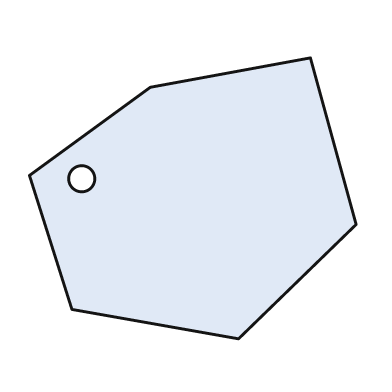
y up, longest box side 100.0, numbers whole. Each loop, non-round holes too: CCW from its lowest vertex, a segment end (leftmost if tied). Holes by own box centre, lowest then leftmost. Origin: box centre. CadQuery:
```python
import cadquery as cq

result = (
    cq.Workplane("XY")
    .moveTo(14.0, -43.0)
    .lineTo(50.0, -8.0)
    .lineTo(36.0, 43.0)
    .lineTo(-13.0, 34.0)
    .lineTo(-50.0, 7.0)
    .lineTo(-37.0, -34.0)
    .close()
    .moveTo(-34.0, 6.0)
    .circle(4.0)
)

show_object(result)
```